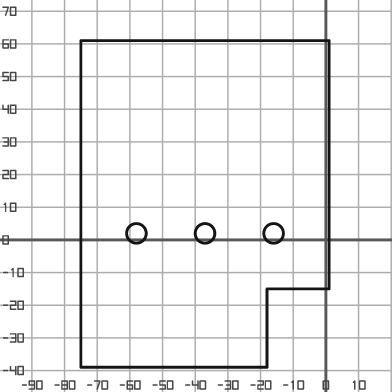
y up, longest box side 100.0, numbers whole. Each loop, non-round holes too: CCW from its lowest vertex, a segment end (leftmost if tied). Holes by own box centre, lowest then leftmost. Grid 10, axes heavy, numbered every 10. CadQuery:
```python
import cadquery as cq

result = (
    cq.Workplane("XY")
    .moveTo(-75.0, -39.0)
    .lineTo(-18.0, -39.0)
    .lineTo(-18.0, -15.0)
    .lineTo(1.0, -15.0)
    .lineTo(1.0, 61.0)
    .lineTo(-75.0, 61.0)
    .close()
    .moveTo(-58.0, 2.0)
    .circle(3.0)
    .moveTo(-37.0, 2.0)
    .circle(3.0)
    .moveTo(-16.0, 2.0)
    .circle(3.0)
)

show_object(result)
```